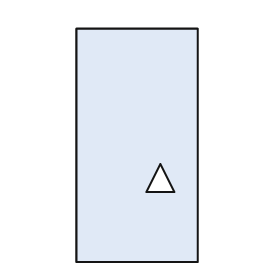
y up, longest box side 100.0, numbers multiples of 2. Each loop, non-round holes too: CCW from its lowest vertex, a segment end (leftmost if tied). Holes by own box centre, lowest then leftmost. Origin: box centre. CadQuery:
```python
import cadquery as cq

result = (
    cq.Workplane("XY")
    .moveTo(-26.0, -50.0)
    .lineTo(26.0, -50.0)
    .lineTo(26.0, 50.0)
    .lineTo(-26.0, 50.0)
    .close()
    .moveTo(4.0, -20.0)
    .lineTo(16.0, -20.0)
    .lineTo(10.0, -8.0)
    .close()
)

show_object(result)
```